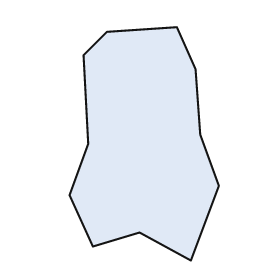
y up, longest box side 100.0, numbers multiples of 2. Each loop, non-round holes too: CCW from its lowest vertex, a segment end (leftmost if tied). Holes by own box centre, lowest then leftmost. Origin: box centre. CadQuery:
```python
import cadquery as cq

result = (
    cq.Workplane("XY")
    .moveTo(20.0, -50.0)
    .lineTo(32.0, -18.0)
    .lineTo(24.0, 4.0)
    .lineTo(22.0, 32.0)
    .lineTo(14.0, 50.0)
    .lineTo(-16.0, 48.0)
    .lineTo(-26.0, 38.0)
    .lineTo(-24.0, 0.0)
    .lineTo(-32.0, -22.0)
    .lineTo(-22.0, -44.0)
    .lineTo(-2.0, -38.0)
    .close()
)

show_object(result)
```